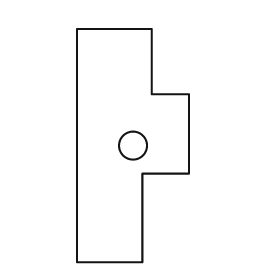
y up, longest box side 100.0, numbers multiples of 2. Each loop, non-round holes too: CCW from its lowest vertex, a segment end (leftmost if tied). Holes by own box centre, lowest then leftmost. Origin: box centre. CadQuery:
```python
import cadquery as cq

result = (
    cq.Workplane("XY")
    .moveTo(-24.0, -50.0)
    .lineTo(4.0, -50.0)
    .lineTo(4.0, -12.0)
    .lineTo(24.0, -12.0)
    .lineTo(24.0, 22.0)
    .lineTo(8.0, 22.0)
    .lineTo(8.0, 50.0)
    .lineTo(-24.0, 50.0)
    .close()
    .moveTo(0.0, 0.0)
    .circle(6.0)
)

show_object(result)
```